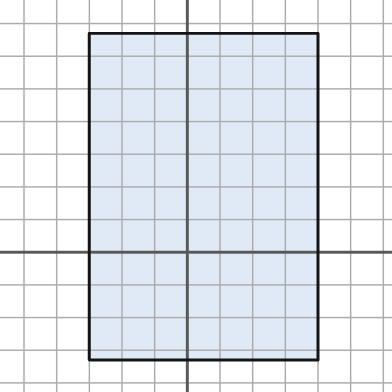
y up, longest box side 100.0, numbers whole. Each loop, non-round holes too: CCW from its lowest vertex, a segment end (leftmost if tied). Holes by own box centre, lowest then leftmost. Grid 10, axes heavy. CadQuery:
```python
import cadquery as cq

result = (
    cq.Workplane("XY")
    .moveTo(-30.0, -33.0)
    .lineTo(40.0, -33.0)
    .lineTo(40.0, 67.0)
    .lineTo(-30.0, 67.0)
    .close()
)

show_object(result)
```